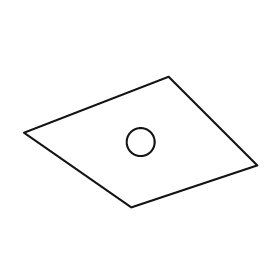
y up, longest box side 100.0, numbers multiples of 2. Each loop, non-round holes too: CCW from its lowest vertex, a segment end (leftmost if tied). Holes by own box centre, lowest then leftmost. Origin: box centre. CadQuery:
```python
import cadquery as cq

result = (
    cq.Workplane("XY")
    .moveTo(-4.0, -28.0)
    .lineTo(50.0, -10.0)
    .lineTo(12.0, 28.0)
    .lineTo(-50.0, 4.0)
    .close()
    .moveTo(0.0, 0.0)
    .circle(6.0)
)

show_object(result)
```